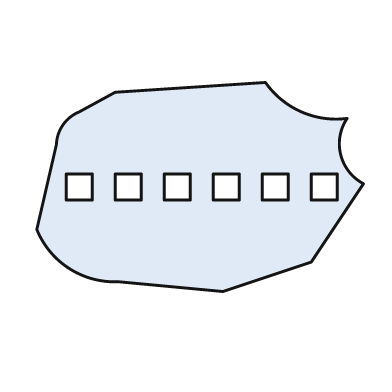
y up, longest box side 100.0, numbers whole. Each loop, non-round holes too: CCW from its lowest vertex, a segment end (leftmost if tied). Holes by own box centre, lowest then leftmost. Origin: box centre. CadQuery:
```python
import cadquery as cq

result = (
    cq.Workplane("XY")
    .moveTo(7.0, -32.0)
    .lineTo(34.0, -23.0)
    .lineTo(50.0, 1.0)
    .threePointArc((43.0, 10.0), (45.0, 21.0))
    .threePointArc((31.0, 23.0), (20.0, 32.0))
    .lineTo(-26.0, 29.0)
    .lineTo(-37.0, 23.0)
    .threePointArc((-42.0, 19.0), (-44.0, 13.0))
    .lineTo(-50.0, -13.0)
    .threePointArc((-40.0, -25.0), (-25.0, -29.0))
    .close()
    .moveTo(-41.0, -4.0)
    .lineTo(-33.0, -4.0)
    .lineTo(-33.0, 4.0)
    .lineTo(-41.0, 4.0)
    .close()
    .moveTo(-26.0, -4.0)
    .lineTo(-18.0, -4.0)
    .lineTo(-18.0, 4.0)
    .lineTo(-26.0, 4.0)
    .close()
    .moveTo(-11.0, -4.0)
    .lineTo(-3.0, -4.0)
    .lineTo(-3.0, 4.0)
    .lineTo(-11.0, 4.0)
    .close()
    .moveTo(4.0, -4.0)
    .lineTo(12.0, -4.0)
    .lineTo(12.0, 4.0)
    .lineTo(4.0, 4.0)
    .close()
    .moveTo(19.0, -4.0)
    .lineTo(27.0, -4.0)
    .lineTo(27.0, 4.0)
    .lineTo(19.0, 4.0)
    .close()
    .moveTo(34.0, -4.0)
    .lineTo(42.0, -4.0)
    .lineTo(42.0, 4.0)
    .lineTo(34.0, 4.0)
    .close()
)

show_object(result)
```